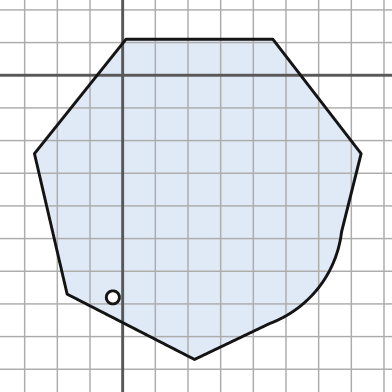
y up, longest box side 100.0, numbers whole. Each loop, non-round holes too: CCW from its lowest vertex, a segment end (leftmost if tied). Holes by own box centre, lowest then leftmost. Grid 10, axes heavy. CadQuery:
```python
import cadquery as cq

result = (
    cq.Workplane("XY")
    .moveTo(22.0, -87.0)
    .lineTo(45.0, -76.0)
    .threePointArc((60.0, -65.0), (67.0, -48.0))
    .lineTo(73.0, -24.0)
    .lineTo(46.0, 11.0)
    .lineTo(1.0, 11.0)
    .lineTo(-27.0, -24.0)
    .lineTo(-17.0, -67.0)
    .close()
    .moveTo(-3.0, -68.0)
    .circle(2.0)
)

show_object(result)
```